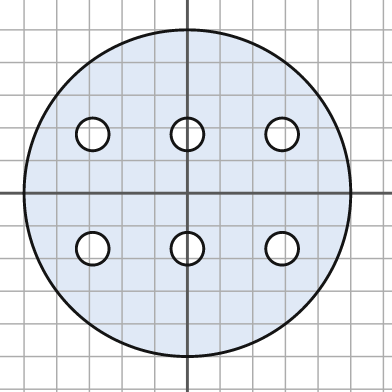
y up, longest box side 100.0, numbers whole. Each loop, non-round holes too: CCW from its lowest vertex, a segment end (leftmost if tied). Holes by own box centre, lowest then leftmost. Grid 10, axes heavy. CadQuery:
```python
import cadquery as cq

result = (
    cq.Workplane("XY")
    .moveTo(0.0, 0.0)
    .circle(50.0)
    .moveTo(-29.0, -17.0)
    .circle(5.0)
    .moveTo(0.0, -17.0)
    .circle(5.0)
    .moveTo(29.0, -17.0)
    .circle(5.0)
    .moveTo(-29.0, 18.0)
    .circle(5.0)
    .moveTo(0.0, 18.0)
    .circle(5.0)
    .moveTo(29.0, 18.0)
    .circle(5.0)
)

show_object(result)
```